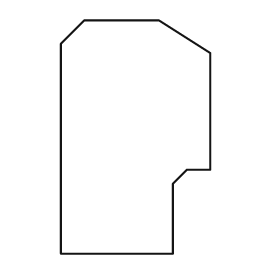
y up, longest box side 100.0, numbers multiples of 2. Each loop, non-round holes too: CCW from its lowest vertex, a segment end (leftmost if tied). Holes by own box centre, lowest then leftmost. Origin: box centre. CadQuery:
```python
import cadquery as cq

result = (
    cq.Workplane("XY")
    .moveTo(-32.0, -50.0)
    .lineTo(16.0, -50.0)
    .lineTo(16.0, -20.0)
    .lineTo(22.0, -14.0)
    .lineTo(32.0, -14.0)
    .lineTo(32.0, 36.0)
    .lineTo(10.0, 50.0)
    .lineTo(-22.0, 50.0)
    .lineTo(-32.0, 40.0)
    .close()
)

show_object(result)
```